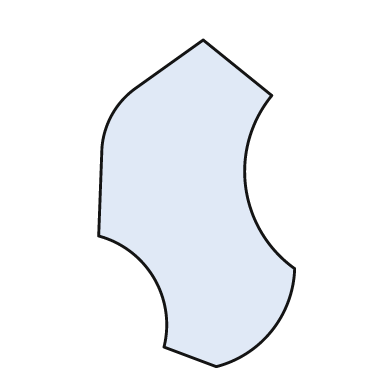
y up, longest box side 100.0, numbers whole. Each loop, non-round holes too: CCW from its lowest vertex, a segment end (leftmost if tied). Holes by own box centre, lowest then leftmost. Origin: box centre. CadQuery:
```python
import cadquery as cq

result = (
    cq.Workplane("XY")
    .moveTo(6.0, -50.0)
    .threePointArc((23.0, -39.0), (30.0, -20.0))
    .threePointArc((15.0, 5.0), (23.0, 33.0))
    .lineTo(2.0, 50.0)
    .lineTo(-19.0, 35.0)
    .threePointArc((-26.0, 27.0), (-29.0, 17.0))
    .lineTo(-30.0, -10.0)
    .threePointArc((-13.0, -23.0), (-10.0, -44.0))
    .close()
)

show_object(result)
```